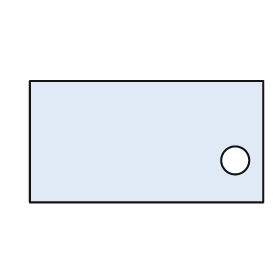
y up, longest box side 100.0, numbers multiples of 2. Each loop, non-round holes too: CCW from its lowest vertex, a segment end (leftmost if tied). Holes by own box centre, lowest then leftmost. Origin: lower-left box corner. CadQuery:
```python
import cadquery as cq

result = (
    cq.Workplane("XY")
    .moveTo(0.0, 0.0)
    .lineTo(100.0, 0.0)
    .lineTo(100.0, 52.0)
    .lineTo(0.0, 52.0)
    .close()
    .moveTo(88.0, 18.0)
    .circle(6.0)
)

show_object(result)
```